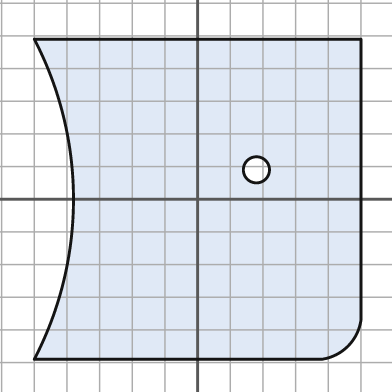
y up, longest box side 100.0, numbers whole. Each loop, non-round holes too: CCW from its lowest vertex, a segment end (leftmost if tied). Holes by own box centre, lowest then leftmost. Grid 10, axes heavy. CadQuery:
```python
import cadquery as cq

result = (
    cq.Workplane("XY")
    .moveTo(-50.0, -49.0)
    .lineTo(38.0, -49.0)
    .threePointArc((46.0, -45.0), (50.0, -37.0))
    .lineTo(50.0, 49.0)
    .lineTo(-50.0, 49.0)
    .threePointArc((-38.0, 0.0), (-50.0, -49.0))
    .close()
    .moveTo(18.0, 9.0)
    .circle(4.0)
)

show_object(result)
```